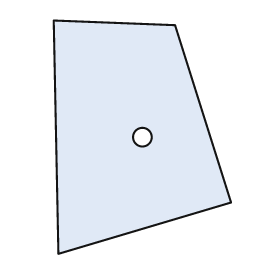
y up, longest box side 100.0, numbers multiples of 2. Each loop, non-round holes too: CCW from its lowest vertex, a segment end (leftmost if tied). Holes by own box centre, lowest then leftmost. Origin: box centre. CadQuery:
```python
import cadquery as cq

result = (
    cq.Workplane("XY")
    .moveTo(-36.0, -50.0)
    .lineTo(38.0, -28.0)
    .lineTo(14.0, 48.0)
    .lineTo(-38.0, 50.0)
    .close()
    .moveTo(0.0, 0.0)
    .circle(4.0)
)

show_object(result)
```